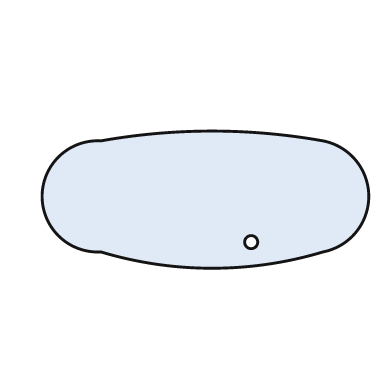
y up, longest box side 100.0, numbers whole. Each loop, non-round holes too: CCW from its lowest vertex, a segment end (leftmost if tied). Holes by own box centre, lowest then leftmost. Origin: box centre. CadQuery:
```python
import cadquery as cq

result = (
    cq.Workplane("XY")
    .moveTo(-32.0, -16.0)
    .threePointArc((2.0, -21.0), (36.0, -16.0))
    .threePointArc((50.0, 1.0), (36.0, 18.0))
    .threePointArc((2.0, 21.0), (-32.0, 18.0))
    .threePointArc((-50.0, 1.0), (-32.0, -16.0))
    .close()
    .moveTo(14.0, -13.0)
    .circle(2.0)
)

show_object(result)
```